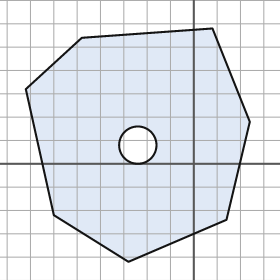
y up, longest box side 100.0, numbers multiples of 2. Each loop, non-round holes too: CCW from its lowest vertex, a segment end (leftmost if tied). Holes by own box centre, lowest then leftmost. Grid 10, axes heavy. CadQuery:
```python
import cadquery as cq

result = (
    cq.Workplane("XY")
    .moveTo(-28.0, -42.0)
    .lineTo(14.0, -24.0)
    .lineTo(24.0, 18.0)
    .lineTo(8.0, 58.0)
    .lineTo(-48.0, 54.0)
    .lineTo(-72.0, 32.0)
    .lineTo(-60.0, -22.0)
    .close()
    .moveTo(-24.0, 8.0)
    .circle(8.0)
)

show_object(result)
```